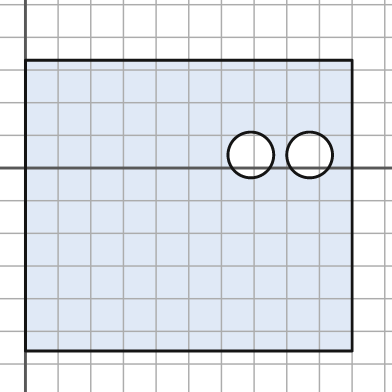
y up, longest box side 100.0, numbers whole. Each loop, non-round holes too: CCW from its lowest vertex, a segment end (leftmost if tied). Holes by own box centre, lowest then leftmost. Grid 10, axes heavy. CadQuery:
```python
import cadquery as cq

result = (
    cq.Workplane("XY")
    .moveTo(0.0, -56.0)
    .lineTo(100.0, -56.0)
    .lineTo(100.0, 33.0)
    .lineTo(0.0, 33.0)
    .close()
    .moveTo(69.0, 4.0)
    .circle(7.0)
    .moveTo(87.0, 4.0)
    .circle(7.0)
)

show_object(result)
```